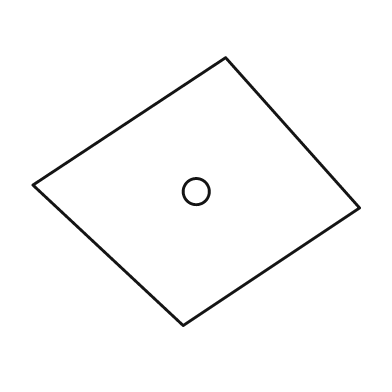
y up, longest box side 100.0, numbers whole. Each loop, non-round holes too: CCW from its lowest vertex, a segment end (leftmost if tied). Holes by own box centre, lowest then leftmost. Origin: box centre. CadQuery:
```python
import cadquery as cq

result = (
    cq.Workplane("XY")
    .moveTo(-4.0, -41.0)
    .lineTo(50.0, -5.0)
    .lineTo(9.0, 41.0)
    .lineTo(-50.0, 2.0)
    .close()
    .moveTo(0.0, 0.0)
    .circle(4.0)
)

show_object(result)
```